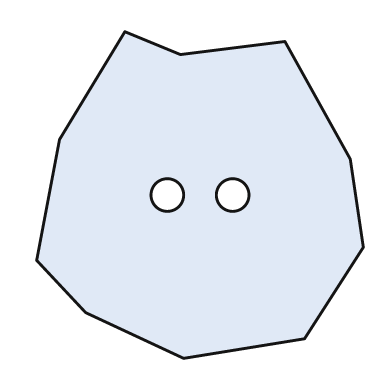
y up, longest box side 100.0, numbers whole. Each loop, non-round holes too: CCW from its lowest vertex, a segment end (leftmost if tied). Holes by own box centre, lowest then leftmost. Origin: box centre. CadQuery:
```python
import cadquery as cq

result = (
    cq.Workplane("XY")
    .moveTo(-5.0, -50.0)
    .lineTo(32.0, -44.0)
    .lineTo(50.0, -16.0)
    .lineTo(46.0, 11.0)
    .lineTo(26.0, 47.0)
    .lineTo(-6.0, 43.0)
    .lineTo(-23.0, 50.0)
    .lineTo(-43.0, 17.0)
    .lineTo(-50.0, -20.0)
    .lineTo(-35.0, -36.0)
    .close()
    .moveTo(-10.0, 0.0)
    .circle(5.0)
    .moveTo(10.0, 0.0)
    .circle(5.0)
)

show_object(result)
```